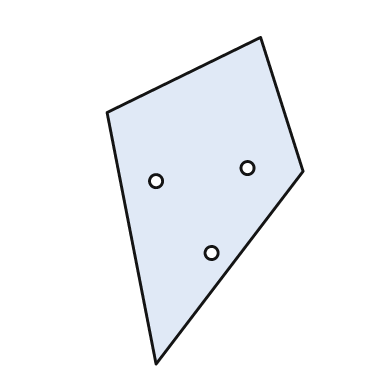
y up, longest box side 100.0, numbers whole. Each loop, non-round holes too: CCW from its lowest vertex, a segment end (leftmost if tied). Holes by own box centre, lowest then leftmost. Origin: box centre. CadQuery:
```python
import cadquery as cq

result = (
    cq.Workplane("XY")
    .moveTo(-15.0, -50.0)
    .lineTo(30.0, 9.0)
    .lineTo(17.0, 50.0)
    .lineTo(-30.0, 27.0)
    .close()
    .moveTo(2.0, -16.0)
    .circle(2.0)
    .moveTo(-15.0, 6.0)
    .circle(2.0)
    .moveTo(13.0, 10.0)
    .circle(2.0)
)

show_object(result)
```